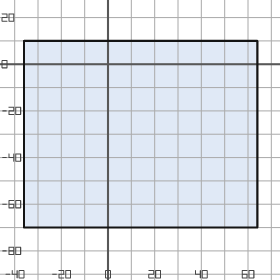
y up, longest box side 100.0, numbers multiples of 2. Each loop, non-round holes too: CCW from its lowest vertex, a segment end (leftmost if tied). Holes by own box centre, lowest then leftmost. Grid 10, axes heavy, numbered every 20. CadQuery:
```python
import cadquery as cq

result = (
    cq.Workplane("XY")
    .moveTo(-36.0, -70.0)
    .lineTo(64.0, -70.0)
    .lineTo(64.0, 10.0)
    .lineTo(-36.0, 10.0)
    .close()
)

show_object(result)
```